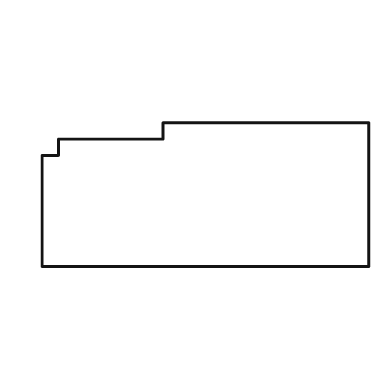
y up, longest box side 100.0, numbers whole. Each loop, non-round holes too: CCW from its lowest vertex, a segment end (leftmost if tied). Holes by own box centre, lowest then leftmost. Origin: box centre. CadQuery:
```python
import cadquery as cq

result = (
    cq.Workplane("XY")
    .moveTo(-50.0, -22.0)
    .lineTo(50.0, -22.0)
    .lineTo(50.0, 22.0)
    .lineTo(-13.0, 22.0)
    .lineTo(-13.0, 17.0)
    .lineTo(-45.0, 17.0)
    .lineTo(-45.0, 12.0)
    .lineTo(-50.0, 12.0)
    .close()
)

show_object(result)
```